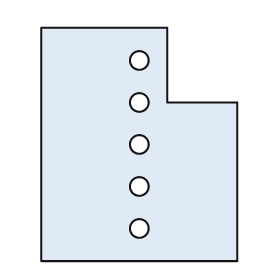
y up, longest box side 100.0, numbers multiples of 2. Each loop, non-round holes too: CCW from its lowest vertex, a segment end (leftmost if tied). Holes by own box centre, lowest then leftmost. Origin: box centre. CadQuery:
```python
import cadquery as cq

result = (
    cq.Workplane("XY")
    .moveTo(-42.0, -50.0)
    .lineTo(42.0, -50.0)
    .lineTo(42.0, 18.0)
    .lineTo(12.0, 18.0)
    .lineTo(12.0, 50.0)
    .lineTo(-42.0, 50.0)
    .close()
    .moveTo(0.0, -36.0)
    .circle(4.0)
    .moveTo(0.0, -18.0)
    .circle(4.0)
    .moveTo(0.0, 0.0)
    .circle(4.0)
    .moveTo(0.0, 18.0)
    .circle(4.0)
    .moveTo(0.0, 36.0)
    .circle(4.0)
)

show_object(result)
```